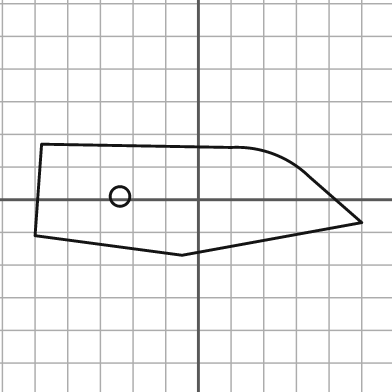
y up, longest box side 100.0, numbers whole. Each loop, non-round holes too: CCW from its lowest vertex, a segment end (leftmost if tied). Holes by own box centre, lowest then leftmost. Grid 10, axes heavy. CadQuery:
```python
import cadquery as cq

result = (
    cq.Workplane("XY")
    .moveTo(-5.0, -17.0)
    .lineTo(50.0, -7.0)
    .lineTo(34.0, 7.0)
    .threePointArc((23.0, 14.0), (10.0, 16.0))
    .lineTo(-48.0, 17.0)
    .lineTo(-50.0, -11.0)
    .close()
    .moveTo(-24.0, 1.0)
    .circle(3.0)
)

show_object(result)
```